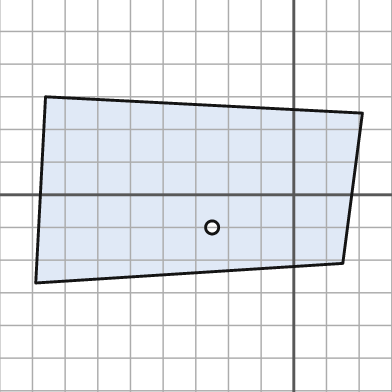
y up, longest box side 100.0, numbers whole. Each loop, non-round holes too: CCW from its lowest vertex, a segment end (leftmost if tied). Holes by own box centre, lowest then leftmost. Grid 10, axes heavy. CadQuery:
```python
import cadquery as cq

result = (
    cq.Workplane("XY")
    .moveTo(-79.0, -27.0)
    .lineTo(15.0, -21.0)
    .lineTo(21.0, 25.0)
    .lineTo(-76.0, 30.0)
    .close()
    .moveTo(-25.0, -10.0)
    .circle(2.0)
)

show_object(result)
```